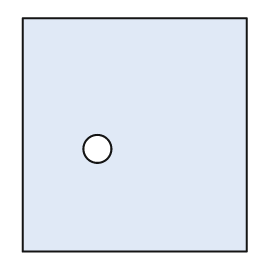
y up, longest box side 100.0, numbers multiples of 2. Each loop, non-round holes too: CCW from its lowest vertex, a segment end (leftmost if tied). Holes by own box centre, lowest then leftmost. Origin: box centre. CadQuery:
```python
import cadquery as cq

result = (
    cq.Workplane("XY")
    .moveTo(-48.0, -50.0)
    .lineTo(48.0, -50.0)
    .lineTo(48.0, 50.0)
    .lineTo(-48.0, 50.0)
    .close()
    .moveTo(-16.0, -6.0)
    .circle(6.0)
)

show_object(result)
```